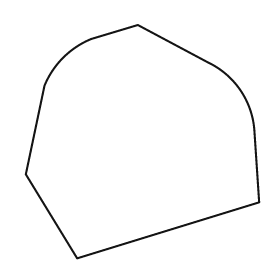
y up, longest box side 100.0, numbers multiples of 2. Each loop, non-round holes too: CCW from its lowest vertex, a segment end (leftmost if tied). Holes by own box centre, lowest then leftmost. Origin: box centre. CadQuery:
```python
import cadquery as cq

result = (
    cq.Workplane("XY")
    .moveTo(-28.0, -50.0)
    .lineTo(50.0, -26.0)
    .lineTo(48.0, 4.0)
    .threePointArc((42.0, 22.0), (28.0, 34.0))
    .lineTo(-2.0, 50.0)
    .lineTo(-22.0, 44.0)
    .threePointArc((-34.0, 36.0), (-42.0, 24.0))
    .lineTo(-50.0, -14.0)
    .close()
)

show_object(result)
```